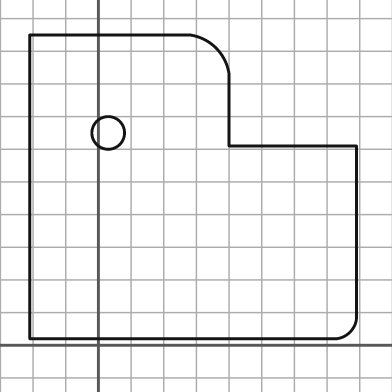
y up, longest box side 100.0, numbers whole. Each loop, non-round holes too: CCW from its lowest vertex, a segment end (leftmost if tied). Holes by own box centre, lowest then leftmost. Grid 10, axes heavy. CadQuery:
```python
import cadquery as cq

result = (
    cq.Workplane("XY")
    .moveTo(-21.0, 2.0)
    .lineTo(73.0, 2.0)
    .threePointArc((77.0, 4.0), (79.0, 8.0))
    .lineTo(79.0, 61.0)
    .lineTo(40.0, 61.0)
    .lineTo(40.0, 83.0)
    .threePointArc((36.0, 91.0), (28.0, 95.0))
    .lineTo(-21.0, 95.0)
    .close()
    .moveTo(3.0, 65.0)
    .circle(5.0)
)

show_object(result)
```